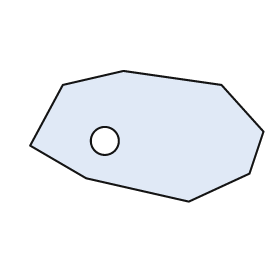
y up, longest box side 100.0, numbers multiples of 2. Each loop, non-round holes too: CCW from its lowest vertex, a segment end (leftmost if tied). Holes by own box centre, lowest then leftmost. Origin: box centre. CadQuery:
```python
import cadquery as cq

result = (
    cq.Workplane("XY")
    .moveTo(18.0, -28.0)
    .lineTo(44.0, -16.0)
    .lineTo(50.0, 2.0)
    .lineTo(32.0, 22.0)
    .lineTo(-10.0, 28.0)
    .lineTo(-36.0, 22.0)
    .lineTo(-50.0, -4.0)
    .lineTo(-26.0, -18.0)
    .close()
    .moveTo(-18.0, -2.0)
    .circle(6.0)
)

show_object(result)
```